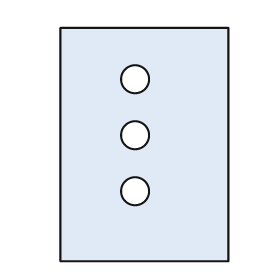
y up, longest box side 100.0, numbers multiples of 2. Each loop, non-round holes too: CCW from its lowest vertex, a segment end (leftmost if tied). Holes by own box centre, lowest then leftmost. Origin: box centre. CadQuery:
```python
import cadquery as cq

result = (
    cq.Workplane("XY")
    .moveTo(-36.0, -50.0)
    .lineTo(36.0, -50.0)
    .lineTo(36.0, 50.0)
    .lineTo(-36.0, 50.0)
    .close()
    .moveTo(-4.0, -20.0)
    .circle(6.0)
    .moveTo(-4.0, 4.0)
    .circle(6.0)
    .moveTo(-4.0, 28.0)
    .circle(6.0)
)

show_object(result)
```